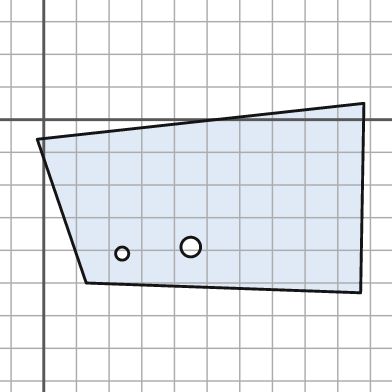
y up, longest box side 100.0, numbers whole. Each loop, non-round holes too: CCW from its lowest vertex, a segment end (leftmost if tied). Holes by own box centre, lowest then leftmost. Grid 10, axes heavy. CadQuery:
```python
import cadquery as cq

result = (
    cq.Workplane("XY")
    .moveTo(97.0, -53.0)
    .lineTo(98.0, 5.0)
    .lineTo(-2.0, -6.0)
    .lineTo(13.0, -50.0)
    .close()
    .moveTo(24.0, -41.0)
    .circle(2.0)
    .moveTo(45.0, -39.0)
    .circle(3.0)
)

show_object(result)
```